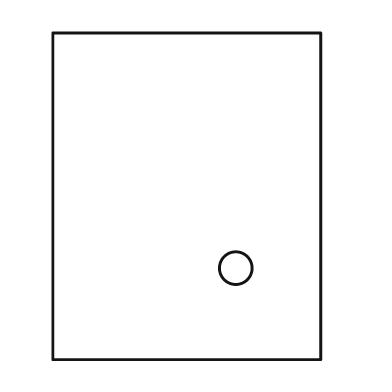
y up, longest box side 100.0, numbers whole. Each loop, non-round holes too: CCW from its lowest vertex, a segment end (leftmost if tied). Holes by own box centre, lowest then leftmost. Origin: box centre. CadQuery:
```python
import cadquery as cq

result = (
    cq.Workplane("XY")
    .moveTo(-41.0, -50.0)
    .lineTo(41.0, -50.0)
    .lineTo(41.0, 50.0)
    .lineTo(-41.0, 50.0)
    .close()
    .moveTo(15.0, -22.0)
    .circle(5.0)
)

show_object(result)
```